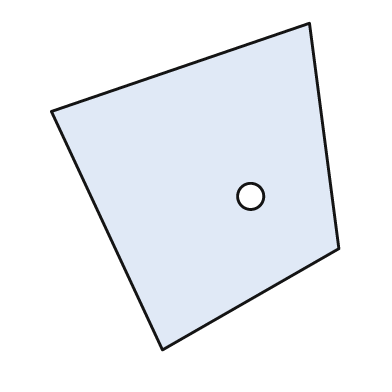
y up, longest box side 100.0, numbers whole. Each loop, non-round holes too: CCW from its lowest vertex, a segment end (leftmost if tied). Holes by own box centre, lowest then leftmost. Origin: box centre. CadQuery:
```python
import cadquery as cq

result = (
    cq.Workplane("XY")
    .moveTo(-10.0, -50.0)
    .lineTo(44.0, -19.0)
    .lineTo(35.0, 50.0)
    .lineTo(-44.0, 23.0)
    .close()
    .moveTo(17.0, -3.0)
    .circle(4.0)
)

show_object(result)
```